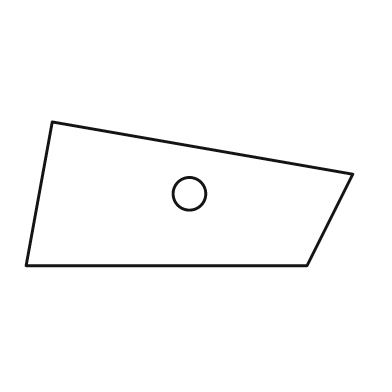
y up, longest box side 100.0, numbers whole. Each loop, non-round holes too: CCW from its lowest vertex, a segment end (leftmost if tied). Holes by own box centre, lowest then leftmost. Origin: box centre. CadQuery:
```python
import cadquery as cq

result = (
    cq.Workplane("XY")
    .moveTo(-50.0, -22.0)
    .lineTo(36.0, -22.0)
    .lineTo(50.0, 6.0)
    .lineTo(-42.0, 22.0)
    .close()
    .moveTo(0.0, 0.0)
    .circle(5.0)
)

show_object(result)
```